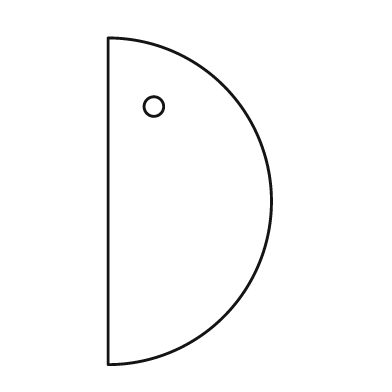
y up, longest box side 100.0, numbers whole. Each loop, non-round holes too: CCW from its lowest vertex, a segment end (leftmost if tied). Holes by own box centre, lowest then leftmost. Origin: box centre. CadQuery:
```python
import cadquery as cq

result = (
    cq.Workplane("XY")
    .moveTo(-25.0, -50.0)
    .threePointArc((25.0, 0.0), (-25.0, 50.0))
    .close()
    .moveTo(-11.0, 29.0)
    .circle(3.0)
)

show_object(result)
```